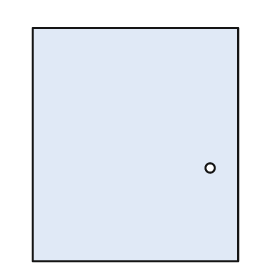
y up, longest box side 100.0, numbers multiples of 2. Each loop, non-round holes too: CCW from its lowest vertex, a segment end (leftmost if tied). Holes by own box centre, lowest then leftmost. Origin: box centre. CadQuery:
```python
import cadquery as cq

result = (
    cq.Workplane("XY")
    .moveTo(-44.0, -50.0)
    .lineTo(44.0, -50.0)
    .lineTo(44.0, 50.0)
    .lineTo(-44.0, 50.0)
    .close()
    .moveTo(32.0, -10.0)
    .circle(2.0)
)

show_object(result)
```